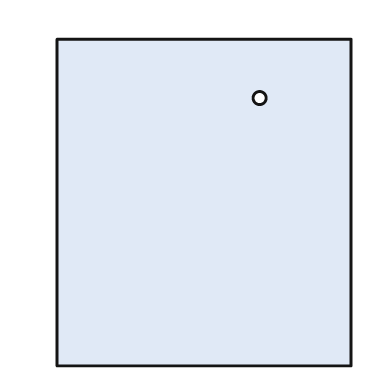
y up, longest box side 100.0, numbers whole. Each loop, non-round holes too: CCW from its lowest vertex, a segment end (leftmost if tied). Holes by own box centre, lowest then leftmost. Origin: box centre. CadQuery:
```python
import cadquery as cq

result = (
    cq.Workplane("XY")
    .moveTo(-45.0, -50.0)
    .lineTo(45.0, -50.0)
    .lineTo(45.0, 50.0)
    .lineTo(-45.0, 50.0)
    .close()
    .moveTo(17.0, 32.0)
    .circle(2.0)
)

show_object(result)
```